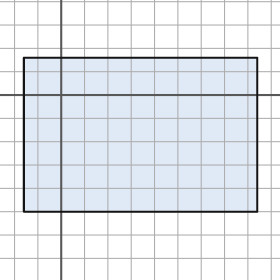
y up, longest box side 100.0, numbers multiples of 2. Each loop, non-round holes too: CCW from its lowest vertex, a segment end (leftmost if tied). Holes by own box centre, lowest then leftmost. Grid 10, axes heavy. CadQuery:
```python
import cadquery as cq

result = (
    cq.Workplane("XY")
    .moveTo(-16.0, -50.0)
    .lineTo(84.0, -50.0)
    .lineTo(84.0, 16.0)
    .lineTo(-16.0, 16.0)
    .close()
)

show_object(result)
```